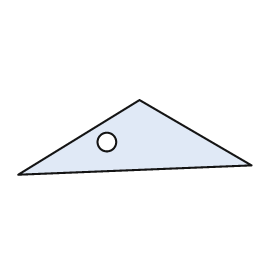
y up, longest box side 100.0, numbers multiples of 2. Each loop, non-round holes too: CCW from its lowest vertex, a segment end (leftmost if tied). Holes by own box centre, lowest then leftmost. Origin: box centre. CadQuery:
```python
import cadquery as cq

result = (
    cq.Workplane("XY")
    .moveTo(-50.0, -16.0)
    .lineTo(50.0, -12.0)
    .lineTo(2.0, 16.0)
    .close()
    .moveTo(-12.0, -2.0)
    .circle(4.0)
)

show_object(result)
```